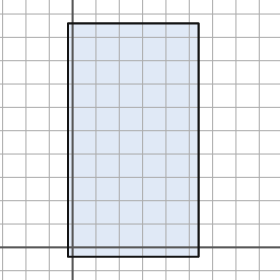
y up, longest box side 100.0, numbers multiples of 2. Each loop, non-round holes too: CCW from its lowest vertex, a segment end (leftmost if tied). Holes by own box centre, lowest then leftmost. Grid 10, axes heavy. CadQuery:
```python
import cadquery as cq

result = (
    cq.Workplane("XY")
    .moveTo(-2.0, -4.0)
    .lineTo(54.0, -4.0)
    .lineTo(54.0, 96.0)
    .lineTo(-2.0, 96.0)
    .close()
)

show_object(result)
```